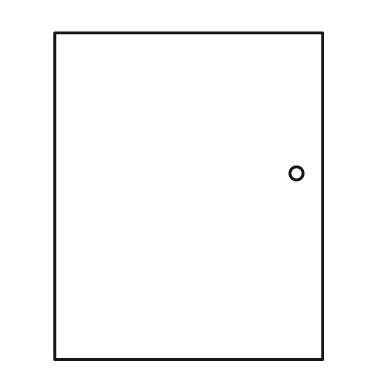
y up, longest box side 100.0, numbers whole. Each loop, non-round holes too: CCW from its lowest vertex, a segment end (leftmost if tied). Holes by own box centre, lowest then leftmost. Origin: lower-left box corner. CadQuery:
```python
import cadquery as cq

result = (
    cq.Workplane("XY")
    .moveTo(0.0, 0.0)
    .lineTo(82.0, 0.0)
    .lineTo(82.0, 100.0)
    .lineTo(0.0, 100.0)
    .close()
    .moveTo(74.0, 57.0)
    .circle(2.0)
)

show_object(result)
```